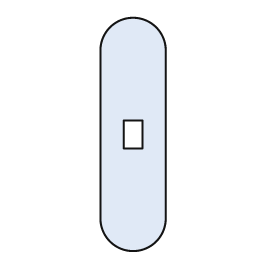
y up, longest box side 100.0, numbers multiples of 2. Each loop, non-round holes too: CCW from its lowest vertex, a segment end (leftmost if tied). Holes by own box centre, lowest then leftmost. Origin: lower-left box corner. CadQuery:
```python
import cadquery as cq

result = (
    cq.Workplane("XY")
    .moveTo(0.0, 14.0)
    .threePointArc((14.0, 0.0), (28.0, 14.0))
    .lineTo(28.0, 86.0)
    .threePointArc((14.0, 100.0), (0.0, 86.0))
    .close()
    .moveTo(10.0, 44.0)
    .lineTo(18.0, 44.0)
    .lineTo(18.0, 56.0)
    .lineTo(10.0, 56.0)
    .close()
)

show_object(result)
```